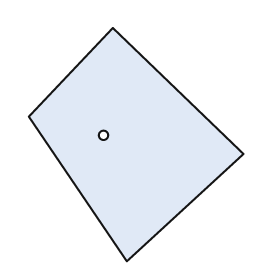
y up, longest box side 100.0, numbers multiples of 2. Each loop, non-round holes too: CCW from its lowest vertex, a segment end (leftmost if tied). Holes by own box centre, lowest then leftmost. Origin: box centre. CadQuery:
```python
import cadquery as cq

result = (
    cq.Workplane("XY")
    .moveTo(-4.0, -50.0)
    .lineTo(46.0, -4.0)
    .lineTo(-10.0, 50.0)
    .lineTo(-46.0, 12.0)
    .close()
    .moveTo(-14.0, 4.0)
    .circle(2.0)
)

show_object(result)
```